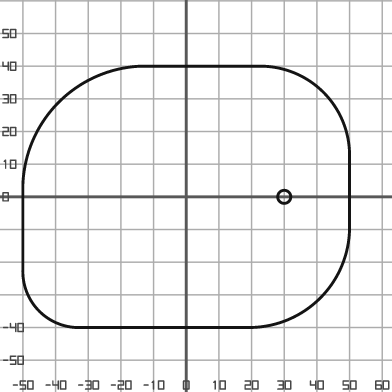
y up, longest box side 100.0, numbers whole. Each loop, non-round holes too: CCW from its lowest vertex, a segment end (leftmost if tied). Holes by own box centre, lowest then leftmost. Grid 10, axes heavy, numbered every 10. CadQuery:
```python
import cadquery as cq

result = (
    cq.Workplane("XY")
    .moveTo(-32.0, -40.0)
    .lineTo(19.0, -40.0)
    .threePointArc((41.0, -31.0), (50.0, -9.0))
    .lineTo(50.0, 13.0)
    .threePointArc((42.0, 32.0), (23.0, 40.0))
    .lineTo(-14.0, 40.0)
    .threePointArc((-39.0, 29.0), (-50.0, 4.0))
    .lineTo(-50.0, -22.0)
    .threePointArc((-45.0, -35.0), (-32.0, -40.0))
    .close()
    .moveTo(30.0, 0.0)
    .circle(2.0)
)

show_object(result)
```